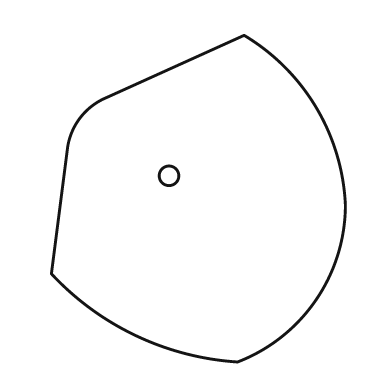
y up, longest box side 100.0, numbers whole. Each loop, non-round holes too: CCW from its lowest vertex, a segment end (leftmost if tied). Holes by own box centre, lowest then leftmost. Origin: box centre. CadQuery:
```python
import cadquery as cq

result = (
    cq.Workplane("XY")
    .moveTo(12.0, -50.0)
    .threePointArc((36.0, -31.0), (45.0, -2.0))
    .threePointArc((36.0, 28.0), (14.0, 50.0))
    .lineTo(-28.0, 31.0)
    .threePointArc((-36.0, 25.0), (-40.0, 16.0))
    .lineTo(-45.0, -23.0)
    .threePointArc((-19.0, -42.0), (12.0, -50.0))
    .close()
    .moveTo(-9.0, 7.0)
    .circle(3.0)
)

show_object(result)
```